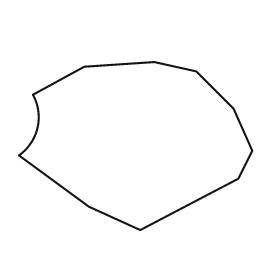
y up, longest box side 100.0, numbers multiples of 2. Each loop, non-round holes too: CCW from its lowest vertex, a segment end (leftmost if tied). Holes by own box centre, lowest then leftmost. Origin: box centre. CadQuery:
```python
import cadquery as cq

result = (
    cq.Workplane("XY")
    .moveTo(2.0, -36.0)
    .lineTo(44.0, -14.0)
    .lineTo(50.0, -2.0)
    .lineTo(42.0, 16.0)
    .lineTo(26.0, 32.0)
    .lineTo(8.0, 36.0)
    .lineTo(-22.0, 34.0)
    .lineTo(-44.0, 22.0)
    .threePointArc((-42.0, 8.0), (-50.0, -4.0))
    .lineTo(-20.0, -26.0)
    .close()
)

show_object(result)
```